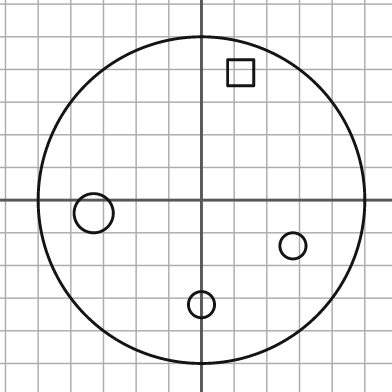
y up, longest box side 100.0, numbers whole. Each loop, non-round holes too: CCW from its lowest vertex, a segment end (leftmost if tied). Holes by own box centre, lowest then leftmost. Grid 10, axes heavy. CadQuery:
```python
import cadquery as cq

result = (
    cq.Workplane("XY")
    .moveTo(0.0, 0.0)
    .circle(50.0)
    .moveTo(0.0, -32.0)
    .circle(4.0)
    .moveTo(28.0, -14.0)
    .circle(4.0)
    .moveTo(-33.0, -4.0)
    .circle(6.0)
    .moveTo(8.0, 35.0)
    .lineTo(16.0, 35.0)
    .lineTo(16.0, 43.0)
    .lineTo(8.0, 43.0)
    .close()
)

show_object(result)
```